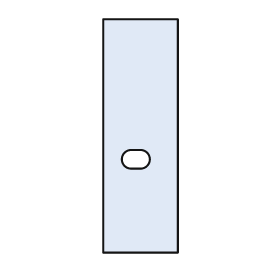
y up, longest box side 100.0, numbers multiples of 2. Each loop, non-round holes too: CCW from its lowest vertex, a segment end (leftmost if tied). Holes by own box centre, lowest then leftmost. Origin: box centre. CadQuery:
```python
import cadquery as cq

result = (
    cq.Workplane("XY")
    .moveTo(-16.0, -50.0)
    .lineTo(16.0, -50.0)
    .lineTo(16.0, 50.0)
    .lineTo(-16.0, 50.0)
    .close()
    .moveTo(-4.0, -14.0)
    .lineTo(0.0, -14.0)
    .threePointArc((4.0, -10.0), (0.0, -6.0))
    .lineTo(-4.0, -6.0)
    .threePointArc((-8.0, -10.0), (-4.0, -14.0))
    .close()
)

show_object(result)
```